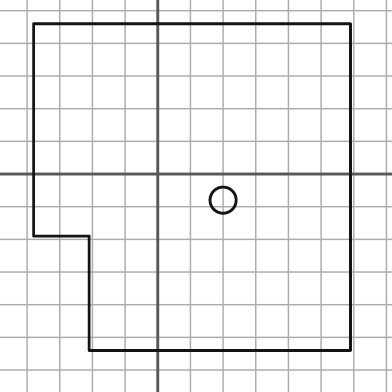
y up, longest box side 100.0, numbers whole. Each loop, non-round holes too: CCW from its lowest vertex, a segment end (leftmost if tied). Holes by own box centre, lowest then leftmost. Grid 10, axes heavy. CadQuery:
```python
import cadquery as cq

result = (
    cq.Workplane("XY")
    .moveTo(-21.0, -54.0)
    .lineTo(59.0, -54.0)
    .lineTo(59.0, 46.0)
    .lineTo(-38.0, 46.0)
    .lineTo(-38.0, -19.0)
    .lineTo(-21.0, -19.0)
    .close()
    .moveTo(20.0, -8.0)
    .circle(4.0)
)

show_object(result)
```